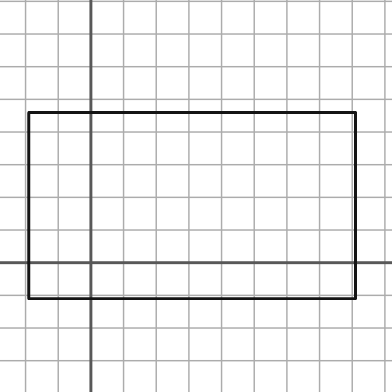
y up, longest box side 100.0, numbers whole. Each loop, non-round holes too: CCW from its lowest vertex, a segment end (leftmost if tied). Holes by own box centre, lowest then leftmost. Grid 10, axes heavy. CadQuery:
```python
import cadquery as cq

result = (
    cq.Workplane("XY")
    .moveTo(-19.0, -11.0)
    .lineTo(81.0, -11.0)
    .lineTo(81.0, 46.0)
    .lineTo(-19.0, 46.0)
    .close()
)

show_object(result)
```